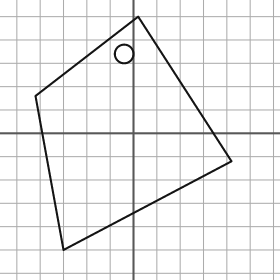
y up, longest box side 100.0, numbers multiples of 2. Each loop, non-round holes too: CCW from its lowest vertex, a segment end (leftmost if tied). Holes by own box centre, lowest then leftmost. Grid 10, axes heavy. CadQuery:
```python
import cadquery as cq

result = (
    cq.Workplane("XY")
    .moveTo(-30.0, -50.0)
    .lineTo(42.0, -12.0)
    .lineTo(2.0, 50.0)
    .lineTo(-42.0, 16.0)
    .close()
    .moveTo(-4.0, 34.0)
    .circle(4.0)
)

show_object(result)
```